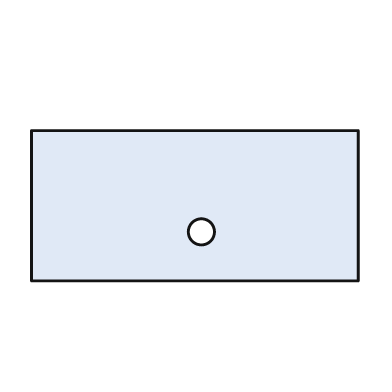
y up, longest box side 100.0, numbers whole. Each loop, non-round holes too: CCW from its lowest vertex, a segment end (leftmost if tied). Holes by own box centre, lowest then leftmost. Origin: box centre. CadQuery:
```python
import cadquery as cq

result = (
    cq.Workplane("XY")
    .moveTo(-50.0, -23.0)
    .lineTo(50.0, -23.0)
    .lineTo(50.0, 23.0)
    .lineTo(-50.0, 23.0)
    .close()
    .moveTo(2.0, -8.0)
    .circle(4.0)
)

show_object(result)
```